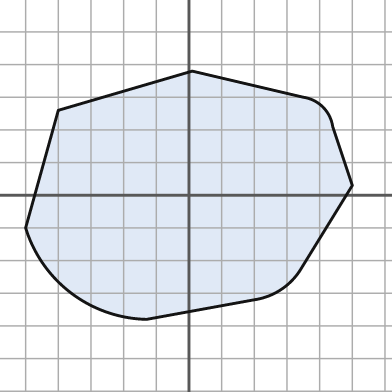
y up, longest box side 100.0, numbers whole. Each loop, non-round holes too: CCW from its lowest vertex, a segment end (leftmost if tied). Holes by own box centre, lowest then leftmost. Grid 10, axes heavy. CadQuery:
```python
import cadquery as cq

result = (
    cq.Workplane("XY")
    .moveTo(-13.0, -38.0)
    .lineTo(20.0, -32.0)
    .threePointArc((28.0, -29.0), (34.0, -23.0))
    .lineTo(50.0, 3.0)
    .lineTo(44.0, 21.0)
    .threePointArc((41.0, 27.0), (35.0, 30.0))
    .lineTo(1.0, 38.0)
    .lineTo(-40.0, 26.0)
    .lineTo(-50.0, -10.0)
    .threePointArc((-36.0, -30.0), (-13.0, -38.0))
    .close()
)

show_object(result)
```